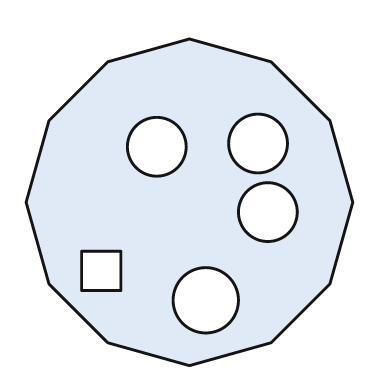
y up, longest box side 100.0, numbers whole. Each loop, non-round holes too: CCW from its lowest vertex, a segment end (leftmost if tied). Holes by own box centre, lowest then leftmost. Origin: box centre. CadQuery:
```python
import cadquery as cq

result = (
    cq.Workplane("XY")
    .moveTo(0.0, -50.0)
    .lineTo(25.0, -43.0)
    .lineTo(43.0, -25.0)
    .lineTo(50.0, 0.0)
    .lineTo(43.0, 25.0)
    .lineTo(25.0, 43.0)
    .lineTo(0.0, 50.0)
    .lineTo(-25.0, 43.0)
    .lineTo(-43.0, 25.0)
    .lineTo(-50.0, 0.0)
    .lineTo(-43.0, -25.0)
    .lineTo(-25.0, -43.0)
    .close()
    .moveTo(5.0, -30.0)
    .circle(10.0)
    .moveTo(-33.0, -27.0)
    .lineTo(-21.0, -27.0)
    .lineTo(-21.0, -15.0)
    .lineTo(-33.0, -15.0)
    .close()
    .moveTo(24.0, -3.0)
    .circle(9.0)
    .moveTo(-10.0, 17.0)
    .circle(9.0)
    .moveTo(21.0, 18.0)
    .circle(9.0)
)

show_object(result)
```